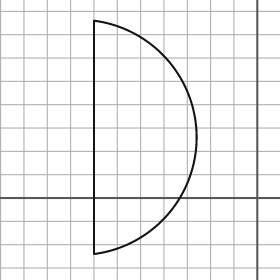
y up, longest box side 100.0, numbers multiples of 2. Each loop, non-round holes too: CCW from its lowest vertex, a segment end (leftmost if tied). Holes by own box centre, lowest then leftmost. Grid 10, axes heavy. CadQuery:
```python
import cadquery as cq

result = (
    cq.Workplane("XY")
    .moveTo(-70.0, -24.0)
    .threePointArc((-26.0, 26.0), (-70.0, 76.0))
    .close()
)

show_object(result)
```